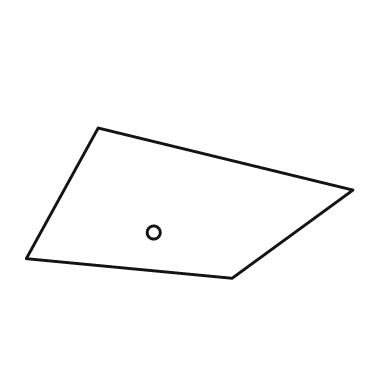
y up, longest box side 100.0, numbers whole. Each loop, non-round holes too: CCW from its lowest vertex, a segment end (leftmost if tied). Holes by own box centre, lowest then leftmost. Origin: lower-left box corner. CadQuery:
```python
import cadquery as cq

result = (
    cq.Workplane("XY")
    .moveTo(63.0, 0.0)
    .lineTo(100.0, 27.0)
    .lineTo(22.0, 46.0)
    .lineTo(0.0, 6.0)
    .close()
    .moveTo(39.0, 14.0)
    .circle(2.0)
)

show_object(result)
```